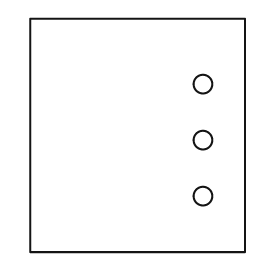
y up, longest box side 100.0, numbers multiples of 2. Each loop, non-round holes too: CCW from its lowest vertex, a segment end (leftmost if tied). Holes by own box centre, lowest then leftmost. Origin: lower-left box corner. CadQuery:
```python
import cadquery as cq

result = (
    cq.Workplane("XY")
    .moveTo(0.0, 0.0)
    .lineTo(92.0, 0.0)
    .lineTo(92.0, 100.0)
    .lineTo(0.0, 100.0)
    .close()
    .moveTo(74.0, 24.0)
    .circle(4.0)
    .moveTo(74.0, 48.0)
    .circle(4.0)
    .moveTo(74.0, 72.0)
    .circle(4.0)
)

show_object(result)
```